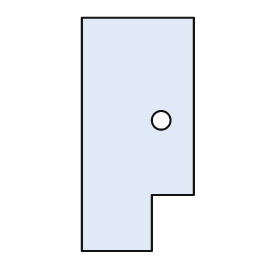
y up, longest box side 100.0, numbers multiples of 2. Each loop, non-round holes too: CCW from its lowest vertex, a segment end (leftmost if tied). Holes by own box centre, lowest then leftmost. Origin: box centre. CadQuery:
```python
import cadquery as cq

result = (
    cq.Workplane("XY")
    .moveTo(-24.0, -50.0)
    .lineTo(6.0, -50.0)
    .lineTo(6.0, -26.0)
    .lineTo(24.0, -26.0)
    .lineTo(24.0, 50.0)
    .lineTo(-24.0, 50.0)
    .close()
    .moveTo(10.0, 6.0)
    .circle(4.0)
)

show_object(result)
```